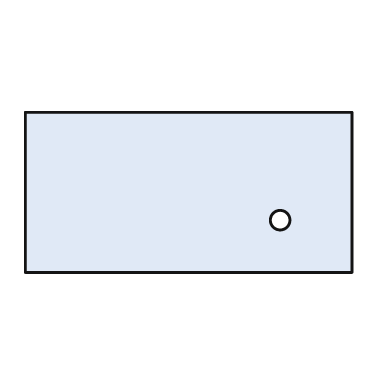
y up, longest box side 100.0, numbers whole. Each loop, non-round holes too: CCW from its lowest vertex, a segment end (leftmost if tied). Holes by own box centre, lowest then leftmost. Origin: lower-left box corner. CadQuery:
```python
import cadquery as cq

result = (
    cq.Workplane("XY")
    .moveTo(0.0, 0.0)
    .lineTo(100.0, 0.0)
    .lineTo(100.0, 49.0)
    .lineTo(0.0, 49.0)
    .close()
    .moveTo(78.0, 16.0)
    .circle(3.0)
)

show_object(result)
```